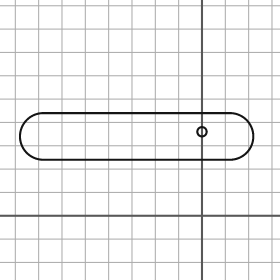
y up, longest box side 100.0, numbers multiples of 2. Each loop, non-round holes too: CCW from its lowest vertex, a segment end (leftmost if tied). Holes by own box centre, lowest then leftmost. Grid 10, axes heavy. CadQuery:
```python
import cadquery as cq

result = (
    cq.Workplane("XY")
    .moveTo(-68.0, 24.0)
    .lineTo(12.0, 24.0)
    .threePointArc((22.0, 34.0), (12.0, 44.0))
    .lineTo(-68.0, 44.0)
    .threePointArc((-78.0, 34.0), (-68.0, 24.0))
    .close()
    .moveTo(0.0, 36.0)
    .circle(2.0)
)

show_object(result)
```